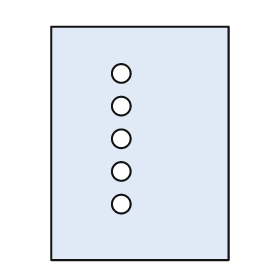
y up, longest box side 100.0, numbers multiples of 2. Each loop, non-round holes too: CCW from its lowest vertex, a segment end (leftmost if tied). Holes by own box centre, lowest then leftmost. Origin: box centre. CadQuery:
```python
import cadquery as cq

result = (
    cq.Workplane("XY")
    .moveTo(-38.0, -50.0)
    .lineTo(38.0, -50.0)
    .lineTo(38.0, 50.0)
    .lineTo(-38.0, 50.0)
    .close()
    .moveTo(-8.0, -26.0)
    .circle(4.0)
    .moveTo(-8.0, -12.0)
    .circle(4.0)
    .moveTo(-8.0, 2.0)
    .circle(4.0)
    .moveTo(-8.0, 16.0)
    .circle(4.0)
    .moveTo(-8.0, 30.0)
    .circle(4.0)
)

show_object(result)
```